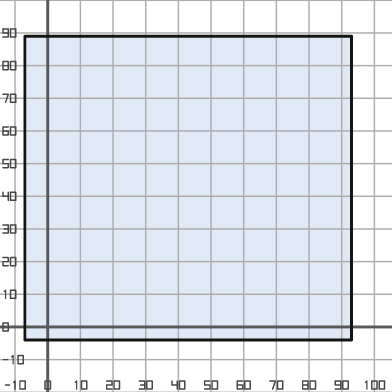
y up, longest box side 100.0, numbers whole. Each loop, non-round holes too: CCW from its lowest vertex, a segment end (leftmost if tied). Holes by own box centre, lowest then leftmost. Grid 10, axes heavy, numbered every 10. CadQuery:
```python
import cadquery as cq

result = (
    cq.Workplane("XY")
    .moveTo(-7.0, -4.0)
    .lineTo(93.0, -4.0)
    .lineTo(93.0, 89.0)
    .lineTo(-7.0, 89.0)
    .close()
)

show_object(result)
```